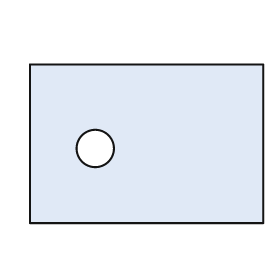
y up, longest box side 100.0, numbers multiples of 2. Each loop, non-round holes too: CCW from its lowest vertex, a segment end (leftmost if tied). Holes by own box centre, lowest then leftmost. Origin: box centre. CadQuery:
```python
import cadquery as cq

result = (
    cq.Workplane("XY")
    .moveTo(-50.0, -34.0)
    .lineTo(50.0, -34.0)
    .lineTo(50.0, 34.0)
    .lineTo(-50.0, 34.0)
    .close()
    .moveTo(-22.0, -2.0)
    .circle(8.0)
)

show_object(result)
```